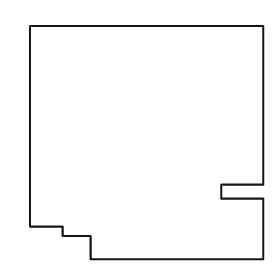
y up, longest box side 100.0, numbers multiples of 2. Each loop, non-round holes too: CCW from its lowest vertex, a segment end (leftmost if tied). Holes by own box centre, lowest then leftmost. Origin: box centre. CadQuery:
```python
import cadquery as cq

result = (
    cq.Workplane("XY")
    .moveTo(-24.0, -50.0)
    .lineTo(50.0, -50.0)
    .lineTo(50.0, -24.0)
    .lineTo(32.0, -24.0)
    .lineTo(32.0, -18.0)
    .lineTo(50.0, -18.0)
    .lineTo(50.0, 50.0)
    .lineTo(-50.0, 50.0)
    .lineTo(-50.0, -36.0)
    .lineTo(-36.0, -36.0)
    .lineTo(-36.0, -40.0)
    .lineTo(-24.0, -40.0)
    .close()
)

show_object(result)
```